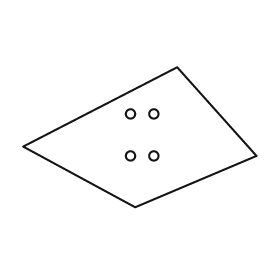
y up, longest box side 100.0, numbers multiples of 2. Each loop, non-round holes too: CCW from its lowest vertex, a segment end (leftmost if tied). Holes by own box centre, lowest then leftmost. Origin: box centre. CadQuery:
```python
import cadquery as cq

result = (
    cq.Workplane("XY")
    .moveTo(-2.0, -30.0)
    .lineTo(50.0, -8.0)
    .lineTo(16.0, 30.0)
    .lineTo(-50.0, -4.0)
    .close()
    .moveTo(-4.0, -8.0)
    .circle(2.0)
    .moveTo(6.0, -8.0)
    .circle(2.0)
    .moveTo(-4.0, 10.0)
    .circle(2.0)
    .moveTo(6.0, 10.0)
    .circle(2.0)
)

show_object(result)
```